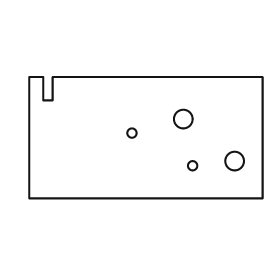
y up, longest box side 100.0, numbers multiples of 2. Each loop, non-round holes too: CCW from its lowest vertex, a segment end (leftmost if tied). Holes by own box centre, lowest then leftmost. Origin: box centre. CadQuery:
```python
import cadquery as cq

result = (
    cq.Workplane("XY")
    .moveTo(-50.0, -26.0)
    .lineTo(50.0, -26.0)
    .lineTo(50.0, 26.0)
    .lineTo(-40.0, 26.0)
    .lineTo(-40.0, 16.0)
    .lineTo(-44.0, 16.0)
    .lineTo(-44.0, 26.0)
    .lineTo(-50.0, 26.0)
    .close()
    .moveTo(20.0, -12.0)
    .circle(2.0)
    .moveTo(38.0, -10.0)
    .circle(4.0)
    .moveTo(-6.0, 2.0)
    .circle(2.0)
    .moveTo(16.0, 8.0)
    .circle(4.0)
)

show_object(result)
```